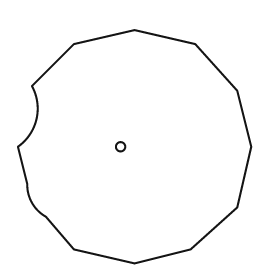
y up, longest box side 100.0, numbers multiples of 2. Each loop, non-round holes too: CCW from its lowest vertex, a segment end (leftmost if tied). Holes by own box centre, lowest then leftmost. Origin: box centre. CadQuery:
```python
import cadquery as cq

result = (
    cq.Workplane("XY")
    .moveTo(0.0, -50.0)
    .lineTo(24.0, -44.0)
    .lineTo(44.0, -26.0)
    .lineTo(50.0, 0.0)
    .lineTo(44.0, 24.0)
    .lineTo(26.0, 44.0)
    .lineTo(0.0, 50.0)
    .lineTo(-26.0, 44.0)
    .lineTo(-44.0, 26.0)
    .threePointArc((-42.0, 12.0), (-50.0, 0.0))
    .lineTo(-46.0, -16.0)
    .threePointArc((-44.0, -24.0), (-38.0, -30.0))
    .lineTo(-26.0, -44.0)
    .close()
    .moveTo(-6.0, 0.0)
    .circle(2.0)
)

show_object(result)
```